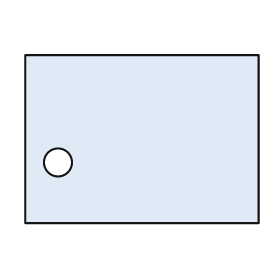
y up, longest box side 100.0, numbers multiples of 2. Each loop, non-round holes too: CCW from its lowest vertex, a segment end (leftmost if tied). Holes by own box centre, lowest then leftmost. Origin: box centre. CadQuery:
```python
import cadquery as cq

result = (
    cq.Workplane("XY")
    .moveTo(-50.0, -36.0)
    .lineTo(50.0, -36.0)
    .lineTo(50.0, 36.0)
    .lineTo(-50.0, 36.0)
    .close()
    .moveTo(-36.0, -10.0)
    .circle(6.0)
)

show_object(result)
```